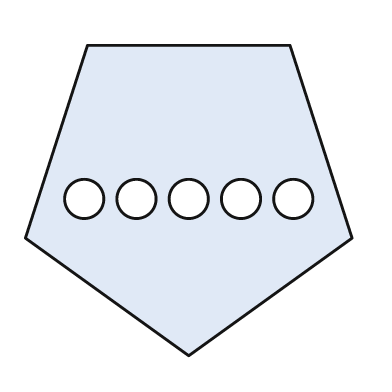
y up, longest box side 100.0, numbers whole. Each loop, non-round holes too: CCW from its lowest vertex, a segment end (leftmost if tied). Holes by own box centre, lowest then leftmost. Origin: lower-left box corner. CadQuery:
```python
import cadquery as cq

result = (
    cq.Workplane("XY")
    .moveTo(50.0, 0.0)
    .lineTo(100.0, 36.0)
    .lineTo(81.0, 95.0)
    .lineTo(19.0, 95.0)
    .lineTo(0.0, 36.0)
    .close()
    .moveTo(18.0, 48.0)
    .circle(6.0)
    .moveTo(34.0, 48.0)
    .circle(6.0)
    .moveTo(50.0, 48.0)
    .circle(6.0)
    .moveTo(66.0, 48.0)
    .circle(6.0)
    .moveTo(82.0, 48.0)
    .circle(6.0)
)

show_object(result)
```